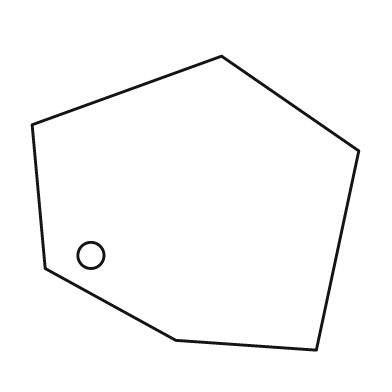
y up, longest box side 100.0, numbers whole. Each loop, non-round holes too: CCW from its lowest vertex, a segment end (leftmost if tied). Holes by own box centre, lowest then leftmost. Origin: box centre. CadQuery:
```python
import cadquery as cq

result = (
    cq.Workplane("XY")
    .moveTo(37.0, -45.0)
    .lineTo(50.0, 16.0)
    .lineTo(8.0, 45.0)
    .lineTo(-50.0, 24.0)
    .lineTo(-46.0, -20.0)
    .lineTo(-6.0, -42.0)
    .close()
    .moveTo(-32.0, -16.0)
    .circle(4.0)
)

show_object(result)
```